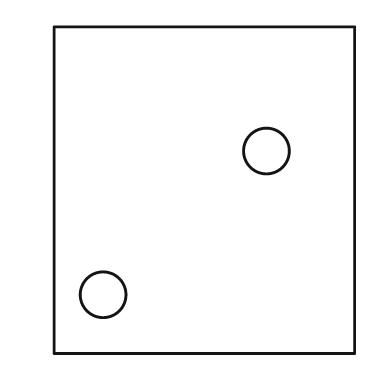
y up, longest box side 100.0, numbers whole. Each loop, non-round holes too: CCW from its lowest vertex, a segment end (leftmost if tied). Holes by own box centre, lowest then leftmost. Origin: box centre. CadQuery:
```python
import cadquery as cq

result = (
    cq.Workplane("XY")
    .moveTo(-46.0, -50.0)
    .lineTo(46.0, -50.0)
    .lineTo(46.0, 50.0)
    .lineTo(-46.0, 50.0)
    .close()
    .moveTo(-31.0, -32.0)
    .circle(7.0)
    .moveTo(19.0, 12.0)
    .circle(7.0)
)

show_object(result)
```